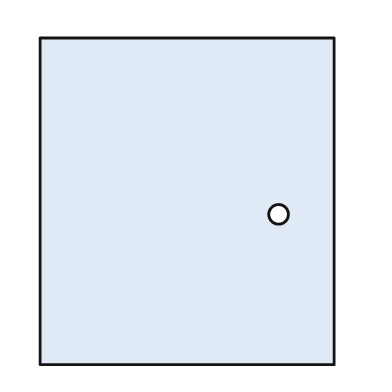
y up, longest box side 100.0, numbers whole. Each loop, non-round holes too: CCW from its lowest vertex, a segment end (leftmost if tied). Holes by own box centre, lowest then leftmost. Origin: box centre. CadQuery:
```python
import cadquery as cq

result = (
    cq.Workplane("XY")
    .moveTo(-45.0, -50.0)
    .lineTo(45.0, -50.0)
    .lineTo(45.0, 50.0)
    .lineTo(-45.0, 50.0)
    .close()
    .moveTo(28.0, -4.0)
    .circle(3.0)
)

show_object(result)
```